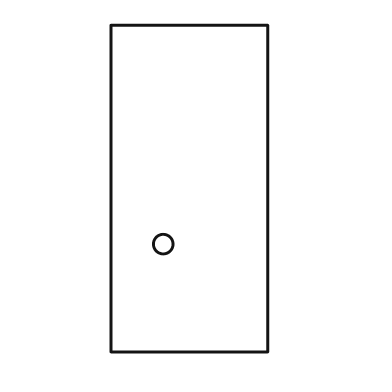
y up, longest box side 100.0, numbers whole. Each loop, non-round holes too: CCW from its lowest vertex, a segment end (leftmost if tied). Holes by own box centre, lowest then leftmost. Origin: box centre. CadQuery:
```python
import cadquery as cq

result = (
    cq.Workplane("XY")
    .moveTo(-24.0, -50.0)
    .lineTo(24.0, -50.0)
    .lineTo(24.0, 50.0)
    .lineTo(-24.0, 50.0)
    .close()
    .moveTo(-8.0, -17.0)
    .circle(3.0)
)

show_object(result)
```